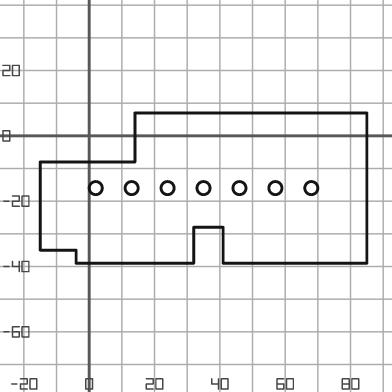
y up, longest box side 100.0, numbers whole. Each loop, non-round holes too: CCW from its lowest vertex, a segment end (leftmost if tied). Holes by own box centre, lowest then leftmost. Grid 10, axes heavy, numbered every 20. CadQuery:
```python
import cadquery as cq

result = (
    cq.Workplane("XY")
    .moveTo(-4.0, -39.0)
    .lineTo(32.0, -39.0)
    .lineTo(32.0, -28.0)
    .lineTo(41.0, -28.0)
    .lineTo(41.0, -39.0)
    .lineTo(85.0, -39.0)
    .lineTo(85.0, 7.0)
    .lineTo(14.0, 7.0)
    .lineTo(14.0, -8.0)
    .lineTo(-15.0, -8.0)
    .lineTo(-15.0, -35.0)
    .lineTo(-4.0, -35.0)
    .close()
    .moveTo(2.0, -16.0)
    .circle(2.0)
    .moveTo(13.0, -16.0)
    .circle(2.0)
    .moveTo(24.0, -16.0)
    .circle(2.0)
    .moveTo(35.0, -16.0)
    .circle(2.0)
    .moveTo(46.0, -16.0)
    .circle(2.0)
    .moveTo(57.0, -16.0)
    .circle(2.0)
    .moveTo(68.0, -16.0)
    .circle(2.0)
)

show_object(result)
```